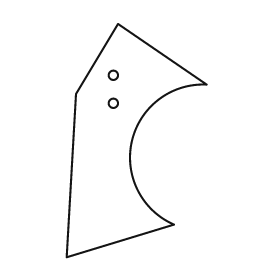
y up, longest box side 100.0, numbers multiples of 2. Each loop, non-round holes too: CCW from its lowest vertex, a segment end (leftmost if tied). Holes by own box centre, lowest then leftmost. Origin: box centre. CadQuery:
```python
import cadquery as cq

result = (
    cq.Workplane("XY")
    .moveTo(-30.0, -50.0)
    .lineTo(16.0, -36.0)
    .threePointArc((-2.0, 0.0), (30.0, 24.0))
    .lineTo(-8.0, 50.0)
    .lineTo(-26.0, 20.0)
    .close()
    .moveTo(-10.0, 16.0)
    .circle(2.0)
    .moveTo(-10.0, 28.0)
    .circle(2.0)
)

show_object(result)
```